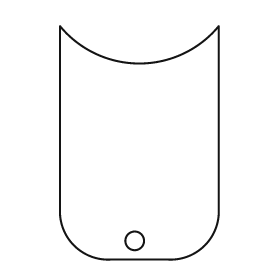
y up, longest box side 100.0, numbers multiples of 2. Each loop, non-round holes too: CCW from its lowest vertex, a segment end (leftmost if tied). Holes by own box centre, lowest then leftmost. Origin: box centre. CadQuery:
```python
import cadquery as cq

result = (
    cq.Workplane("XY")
    .moveTo(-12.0, -50.0)
    .lineTo(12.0, -50.0)
    .threePointArc((28.0, -44.0), (34.0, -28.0))
    .lineTo(34.0, 50.0)
    .threePointArc((0.0, 34.0), (-34.0, 50.0))
    .lineTo(-34.0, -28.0)
    .threePointArc((-28.0, -44.0), (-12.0, -50.0))
    .close()
    .moveTo(-2.0, -42.0)
    .circle(4.0)
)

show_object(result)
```